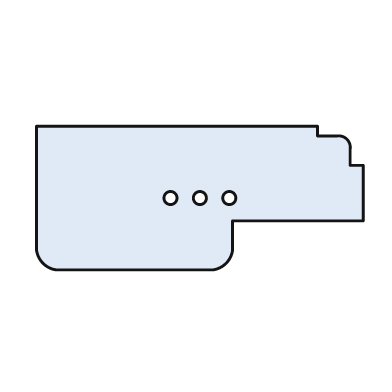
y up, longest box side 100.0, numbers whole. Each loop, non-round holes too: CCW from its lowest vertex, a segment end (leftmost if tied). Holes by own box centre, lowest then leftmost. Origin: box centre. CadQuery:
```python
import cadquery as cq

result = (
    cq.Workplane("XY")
    .moveTo(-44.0, -22.0)
    .lineTo(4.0, -22.0)
    .threePointArc((8.0, -20.0), (10.0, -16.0))
    .lineTo(10.0, -7.0)
    .lineTo(50.0, -7.0)
    .lineTo(50.0, 10.0)
    .lineTo(46.0, 10.0)
    .lineTo(46.0, 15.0)
    .threePointArc((45.0, 18.0), (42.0, 19.0))
    .lineTo(36.0, 19.0)
    .lineTo(36.0, 22.0)
    .lineTo(-50.0, 22.0)
    .lineTo(-50.0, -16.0)
    .threePointArc((-48.0, -20.0), (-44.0, -22.0))
    .close()
    .moveTo(-9.0, 0.0)
    .circle(2.0)
    .moveTo(0.0, 0.0)
    .circle(2.0)
    .moveTo(9.0, 0.0)
    .circle(2.0)
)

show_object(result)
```